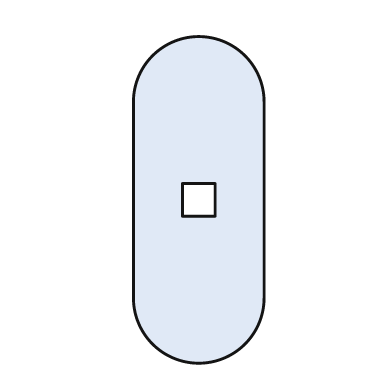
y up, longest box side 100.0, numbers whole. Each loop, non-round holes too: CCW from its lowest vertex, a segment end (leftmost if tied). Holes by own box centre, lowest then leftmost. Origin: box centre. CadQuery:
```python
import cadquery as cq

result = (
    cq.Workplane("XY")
    .moveTo(-20.0, -30.0)
    .threePointArc((0.0, -50.0), (20.0, -30.0))
    .lineTo(20.0, 30.0)
    .threePointArc((0.0, 50.0), (-20.0, 30.0))
    .close()
    .moveTo(-5.0, -5.0)
    .lineTo(5.0, -5.0)
    .lineTo(5.0, 5.0)
    .lineTo(-5.0, 5.0)
    .close()
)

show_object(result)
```